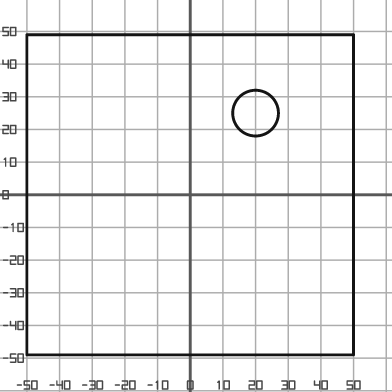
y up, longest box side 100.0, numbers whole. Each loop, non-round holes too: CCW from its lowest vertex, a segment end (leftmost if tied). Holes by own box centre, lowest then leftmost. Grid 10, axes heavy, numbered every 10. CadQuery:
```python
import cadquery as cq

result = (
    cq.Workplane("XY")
    .moveTo(-50.0, -49.0)
    .lineTo(50.0, -49.0)
    .lineTo(50.0, 49.0)
    .lineTo(-50.0, 49.0)
    .close()
    .moveTo(20.0, 25.0)
    .circle(7.0)
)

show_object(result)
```